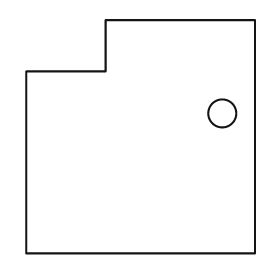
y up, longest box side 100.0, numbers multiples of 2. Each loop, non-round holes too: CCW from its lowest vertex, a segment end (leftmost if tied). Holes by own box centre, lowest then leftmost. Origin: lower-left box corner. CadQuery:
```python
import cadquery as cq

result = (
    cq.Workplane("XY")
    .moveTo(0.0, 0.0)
    .lineTo(98.0, 0.0)
    .lineTo(98.0, 100.0)
    .lineTo(34.0, 100.0)
    .lineTo(34.0, 78.0)
    .lineTo(0.0, 78.0)
    .close()
    .moveTo(84.0, 60.0)
    .circle(6.0)
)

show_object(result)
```